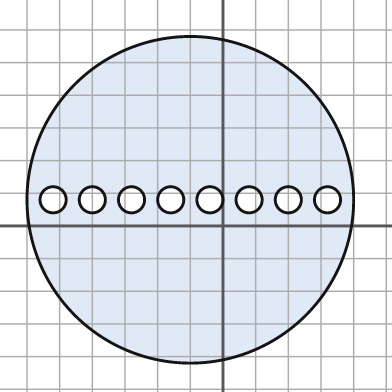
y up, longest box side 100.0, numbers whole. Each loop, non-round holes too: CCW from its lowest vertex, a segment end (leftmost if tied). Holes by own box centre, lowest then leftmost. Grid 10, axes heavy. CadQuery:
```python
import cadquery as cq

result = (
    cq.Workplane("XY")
    .moveTo(-10.0, 8.0)
    .circle(50.0)
    .moveTo(-52.0, 8.0)
    .circle(4.0)
    .moveTo(-40.0, 8.0)
    .circle(4.0)
    .moveTo(-28.0, 8.0)
    .circle(4.0)
    .moveTo(-16.0, 8.0)
    .circle(4.0)
    .moveTo(-4.0, 8.0)
    .circle(4.0)
    .moveTo(8.0, 8.0)
    .circle(4.0)
    .moveTo(20.0, 8.0)
    .circle(4.0)
    .moveTo(32.0, 8.0)
    .circle(4.0)
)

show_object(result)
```